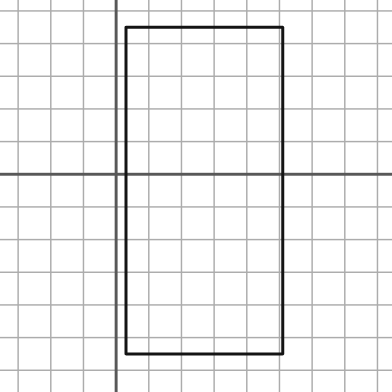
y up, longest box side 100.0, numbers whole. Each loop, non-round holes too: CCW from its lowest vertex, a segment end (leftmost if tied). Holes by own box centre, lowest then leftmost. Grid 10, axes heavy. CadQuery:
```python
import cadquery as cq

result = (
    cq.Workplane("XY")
    .moveTo(3.0, -55.0)
    .lineTo(51.0, -55.0)
    .lineTo(51.0, 45.0)
    .lineTo(3.0, 45.0)
    .close()
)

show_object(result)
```